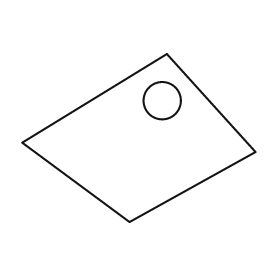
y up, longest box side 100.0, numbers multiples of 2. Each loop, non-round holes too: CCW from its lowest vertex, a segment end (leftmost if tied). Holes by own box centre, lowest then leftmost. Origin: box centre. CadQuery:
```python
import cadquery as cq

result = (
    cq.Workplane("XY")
    .moveTo(-4.0, -36.0)
    .lineTo(50.0, -6.0)
    .lineTo(12.0, 36.0)
    .lineTo(-50.0, -2.0)
    .close()
    .moveTo(10.0, 16.0)
    .circle(8.0)
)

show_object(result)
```